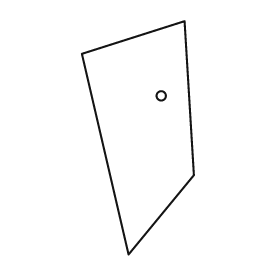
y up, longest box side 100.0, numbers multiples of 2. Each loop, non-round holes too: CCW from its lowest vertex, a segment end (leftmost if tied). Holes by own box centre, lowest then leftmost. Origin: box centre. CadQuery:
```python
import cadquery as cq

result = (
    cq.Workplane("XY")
    .moveTo(-4.0, -50.0)
    .lineTo(24.0, -16.0)
    .lineTo(20.0, 50.0)
    .lineTo(-24.0, 36.0)
    .close()
    .moveTo(10.0, 18.0)
    .circle(2.0)
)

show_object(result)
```